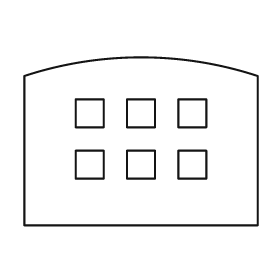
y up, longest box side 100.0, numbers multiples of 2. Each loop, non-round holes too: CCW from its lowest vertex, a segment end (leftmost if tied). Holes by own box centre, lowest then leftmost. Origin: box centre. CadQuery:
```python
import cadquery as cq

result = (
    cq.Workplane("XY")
    .moveTo(-50.0, -36.0)
    .lineTo(50.0, -36.0)
    .lineTo(50.0, 28.0)
    .threePointArc((0.0, 36.0), (-50.0, 28.0))
    .close()
    .moveTo(-28.0, -16.0)
    .lineTo(-16.0, -16.0)
    .lineTo(-16.0, -4.0)
    .lineTo(-28.0, -4.0)
    .close()
    .moveTo(-6.0, -16.0)
    .lineTo(6.0, -16.0)
    .lineTo(6.0, -4.0)
    .lineTo(-6.0, -4.0)
    .close()
    .moveTo(16.0, -16.0)
    .lineTo(28.0, -16.0)
    .lineTo(28.0, -4.0)
    .lineTo(16.0, -4.0)
    .close()
    .moveTo(-28.0, 6.0)
    .lineTo(-16.0, 6.0)
    .lineTo(-16.0, 18.0)
    .lineTo(-28.0, 18.0)
    .close()
    .moveTo(-6.0, 6.0)
    .lineTo(6.0, 6.0)
    .lineTo(6.0, 18.0)
    .lineTo(-6.0, 18.0)
    .close()
    .moveTo(16.0, 6.0)
    .lineTo(28.0, 6.0)
    .lineTo(28.0, 18.0)
    .lineTo(16.0, 18.0)
    .close()
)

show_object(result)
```